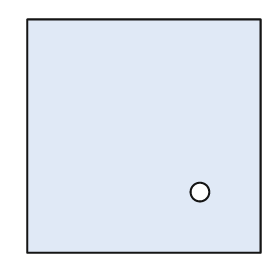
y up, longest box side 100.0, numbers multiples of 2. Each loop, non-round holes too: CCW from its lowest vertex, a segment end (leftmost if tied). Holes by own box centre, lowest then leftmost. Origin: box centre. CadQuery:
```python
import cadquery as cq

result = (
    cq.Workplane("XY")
    .moveTo(-50.0, -50.0)
    .lineTo(50.0, -50.0)
    .lineTo(50.0, 50.0)
    .lineTo(-50.0, 50.0)
    .close()
    .moveTo(24.0, -24.0)
    .circle(4.0)
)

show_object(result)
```